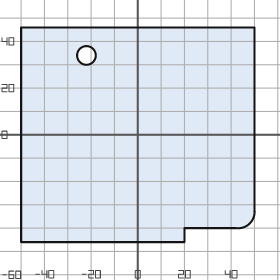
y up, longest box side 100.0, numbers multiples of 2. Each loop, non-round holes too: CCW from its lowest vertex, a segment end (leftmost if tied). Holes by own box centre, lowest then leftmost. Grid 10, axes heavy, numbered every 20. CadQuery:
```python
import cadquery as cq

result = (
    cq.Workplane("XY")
    .moveTo(-50.0, -46.0)
    .lineTo(20.0, -46.0)
    .lineTo(20.0, -40.0)
    .lineTo(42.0, -40.0)
    .threePointArc((48.0, -38.0), (50.0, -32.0))
    .lineTo(50.0, 46.0)
    .lineTo(-50.0, 46.0)
    .close()
    .moveTo(-22.0, 34.0)
    .circle(4.0)
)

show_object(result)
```